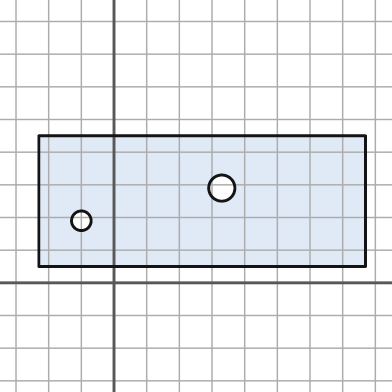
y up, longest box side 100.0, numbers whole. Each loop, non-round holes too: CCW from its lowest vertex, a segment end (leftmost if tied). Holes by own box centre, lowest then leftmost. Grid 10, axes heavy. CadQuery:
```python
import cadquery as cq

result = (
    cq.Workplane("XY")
    .moveTo(-23.0, 5.0)
    .lineTo(77.0, 5.0)
    .lineTo(77.0, 45.0)
    .lineTo(-23.0, 45.0)
    .close()
    .moveTo(-10.0, 19.0)
    .circle(3.0)
    .moveTo(33.0, 29.0)
    .circle(4.0)
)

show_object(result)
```